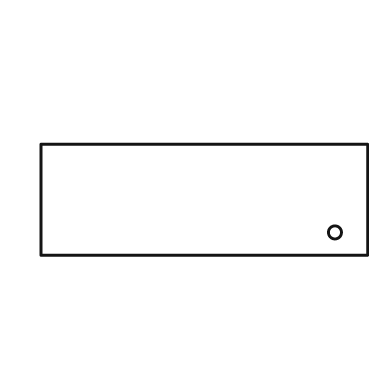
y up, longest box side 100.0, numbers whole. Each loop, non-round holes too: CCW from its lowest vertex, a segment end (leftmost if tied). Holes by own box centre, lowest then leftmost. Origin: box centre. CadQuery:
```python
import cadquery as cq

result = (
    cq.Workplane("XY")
    .moveTo(-50.0, -17.0)
    .lineTo(50.0, -17.0)
    .lineTo(50.0, 17.0)
    .lineTo(-50.0, 17.0)
    .close()
    .moveTo(40.0, -10.0)
    .circle(2.0)
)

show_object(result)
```